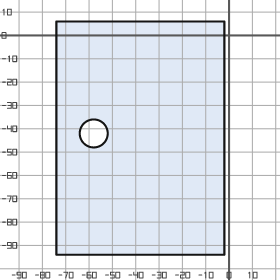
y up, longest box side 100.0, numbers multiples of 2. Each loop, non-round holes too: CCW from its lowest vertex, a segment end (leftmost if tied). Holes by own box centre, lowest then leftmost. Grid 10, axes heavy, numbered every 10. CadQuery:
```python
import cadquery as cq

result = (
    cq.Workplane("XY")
    .moveTo(-74.0, -94.0)
    .lineTo(-2.0, -94.0)
    .lineTo(-2.0, 6.0)
    .lineTo(-74.0, 6.0)
    .close()
    .moveTo(-58.0, -42.0)
    .circle(6.0)
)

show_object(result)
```